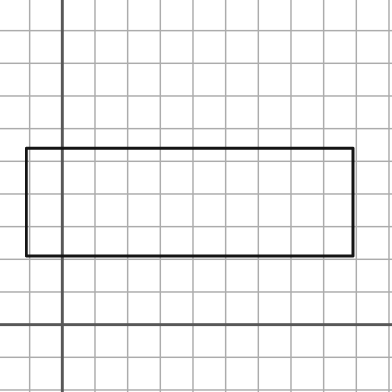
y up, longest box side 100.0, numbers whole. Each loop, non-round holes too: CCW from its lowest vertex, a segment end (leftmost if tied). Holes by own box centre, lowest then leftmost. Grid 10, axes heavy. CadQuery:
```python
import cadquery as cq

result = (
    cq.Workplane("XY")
    .moveTo(-11.0, 21.0)
    .lineTo(89.0, 21.0)
    .lineTo(89.0, 54.0)
    .lineTo(-11.0, 54.0)
    .close()
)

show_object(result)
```